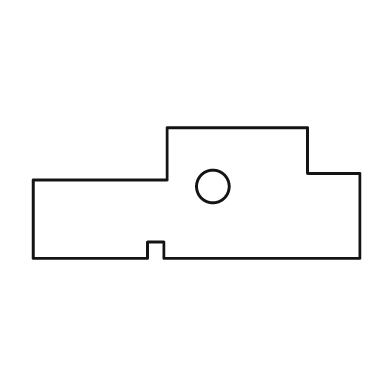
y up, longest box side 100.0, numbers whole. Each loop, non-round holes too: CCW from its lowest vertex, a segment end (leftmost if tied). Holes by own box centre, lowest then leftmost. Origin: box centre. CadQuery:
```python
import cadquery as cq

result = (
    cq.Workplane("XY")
    .moveTo(-50.0, -20.0)
    .lineTo(-15.0, -20.0)
    .lineTo(-15.0, -15.0)
    .lineTo(-10.0, -15.0)
    .lineTo(-10.0, -20.0)
    .lineTo(50.0, -20.0)
    .lineTo(50.0, 6.0)
    .lineTo(34.0, 6.0)
    .lineTo(34.0, 20.0)
    .lineTo(-9.0, 20.0)
    .lineTo(-9.0, 4.0)
    .lineTo(-50.0, 4.0)
    .close()
    .moveTo(5.0, 2.0)
    .circle(5.0)
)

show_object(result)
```